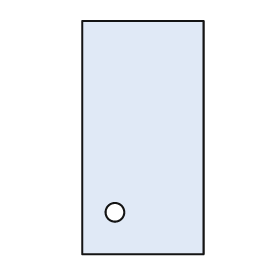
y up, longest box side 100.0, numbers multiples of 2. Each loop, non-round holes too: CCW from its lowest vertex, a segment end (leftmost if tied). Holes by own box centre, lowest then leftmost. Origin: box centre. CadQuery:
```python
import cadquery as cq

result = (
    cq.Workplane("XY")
    .moveTo(-26.0, -50.0)
    .lineTo(26.0, -50.0)
    .lineTo(26.0, 50.0)
    .lineTo(-26.0, 50.0)
    .close()
    .moveTo(-12.0, -32.0)
    .circle(4.0)
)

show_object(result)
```